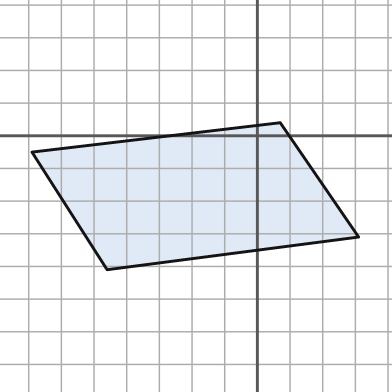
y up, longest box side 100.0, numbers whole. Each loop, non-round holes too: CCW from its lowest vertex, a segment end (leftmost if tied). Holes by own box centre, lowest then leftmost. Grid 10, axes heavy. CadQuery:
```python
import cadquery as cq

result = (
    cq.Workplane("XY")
    .moveTo(-46.0, -41.0)
    .lineTo(31.0, -31.0)
    .lineTo(7.0, 4.0)
    .lineTo(-69.0, -5.0)
    .close()
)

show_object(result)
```